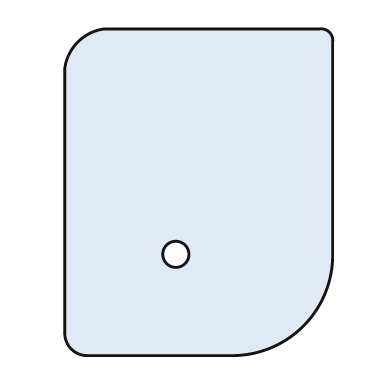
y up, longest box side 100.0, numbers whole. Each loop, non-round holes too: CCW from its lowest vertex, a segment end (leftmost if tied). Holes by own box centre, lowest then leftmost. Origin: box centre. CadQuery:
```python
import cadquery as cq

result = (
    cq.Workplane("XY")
    .moveTo(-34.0, -50.0)
    .lineTo(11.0, -50.0)
    .threePointArc((32.0, -41.0), (41.0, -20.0))
    .lineTo(41.0, 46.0)
    .threePointArc((40.0, 49.0), (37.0, 50.0))
    .lineTo(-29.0, 50.0)
    .threePointArc((-37.0, 46.0), (-41.0, 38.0))
    .lineTo(-41.0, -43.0)
    .threePointArc((-39.0, -48.0), (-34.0, -50.0))
    .close()
    .moveTo(-7.0, -19.0)
    .circle(4.0)
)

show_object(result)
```